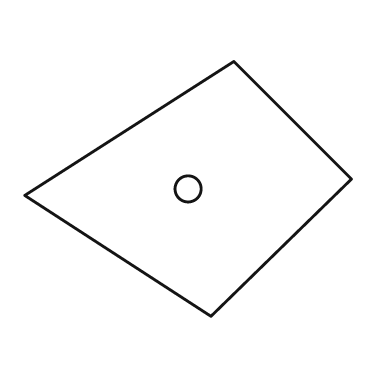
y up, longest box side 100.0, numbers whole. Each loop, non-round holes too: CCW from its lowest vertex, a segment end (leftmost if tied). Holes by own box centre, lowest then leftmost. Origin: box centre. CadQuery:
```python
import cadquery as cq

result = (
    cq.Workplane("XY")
    .moveTo(7.0, -39.0)
    .lineTo(50.0, 3.0)
    .lineTo(14.0, 39.0)
    .lineTo(-50.0, -2.0)
    .close()
    .moveTo(0.0, 0.0)
    .circle(4.0)
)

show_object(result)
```